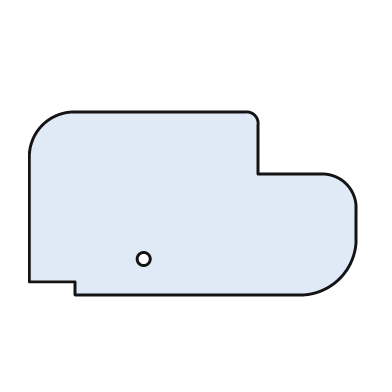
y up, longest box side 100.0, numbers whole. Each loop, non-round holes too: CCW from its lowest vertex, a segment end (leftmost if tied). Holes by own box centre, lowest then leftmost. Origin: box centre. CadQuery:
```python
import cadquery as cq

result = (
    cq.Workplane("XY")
    .moveTo(-36.0, -28.0)
    .lineTo(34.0, -28.0)
    .threePointArc((45.0, -23.0), (50.0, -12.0))
    .lineTo(50.0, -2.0)
    .threePointArc((47.0, 6.0), (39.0, 9.0))
    .lineTo(20.0, 9.0)
    .lineTo(20.0, 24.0)
    .threePointArc((19.0, 27.0), (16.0, 28.0))
    .lineTo(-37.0, 28.0)
    .threePointArc((-46.0, 24.0), (-50.0, 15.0))
    .lineTo(-50.0, -24.0)
    .lineTo(-36.0, -24.0)
    .close()
    .moveTo(-15.0, -17.0)
    .circle(2.0)
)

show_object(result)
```